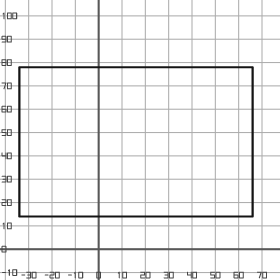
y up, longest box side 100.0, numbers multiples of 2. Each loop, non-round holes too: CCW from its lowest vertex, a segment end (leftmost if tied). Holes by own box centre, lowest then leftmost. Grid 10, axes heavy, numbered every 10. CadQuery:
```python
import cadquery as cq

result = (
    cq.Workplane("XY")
    .moveTo(-34.0, 14.0)
    .lineTo(66.0, 14.0)
    .lineTo(66.0, 78.0)
    .lineTo(-34.0, 78.0)
    .close()
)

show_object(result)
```